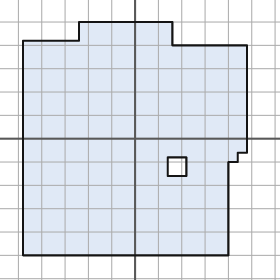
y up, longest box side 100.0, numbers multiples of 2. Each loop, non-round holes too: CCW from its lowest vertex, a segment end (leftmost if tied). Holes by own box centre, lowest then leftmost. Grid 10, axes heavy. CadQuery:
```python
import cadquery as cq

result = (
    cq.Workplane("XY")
    .moveTo(-48.0, -50.0)
    .lineTo(40.0, -50.0)
    .lineTo(40.0, -10.0)
    .lineTo(44.0, -10.0)
    .lineTo(44.0, -6.0)
    .lineTo(48.0, -6.0)
    .lineTo(48.0, 40.0)
    .lineTo(16.0, 40.0)
    .lineTo(16.0, 50.0)
    .lineTo(-24.0, 50.0)
    .lineTo(-24.0, 42.0)
    .lineTo(-48.0, 42.0)
    .close()
    .moveTo(14.0, -16.0)
    .lineTo(22.0, -16.0)
    .lineTo(22.0, -8.0)
    .lineTo(14.0, -8.0)
    .close()
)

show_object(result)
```